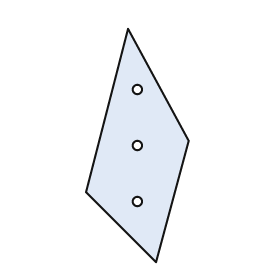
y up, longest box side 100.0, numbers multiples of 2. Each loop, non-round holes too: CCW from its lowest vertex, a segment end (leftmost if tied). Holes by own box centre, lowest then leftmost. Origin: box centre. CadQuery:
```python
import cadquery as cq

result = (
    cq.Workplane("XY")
    .moveTo(8.0, -50.0)
    .lineTo(22.0, 2.0)
    .lineTo(-4.0, 50.0)
    .lineTo(-22.0, -20.0)
    .close()
    .moveTo(0.0, -24.0)
    .circle(2.0)
    .moveTo(0.0, 0.0)
    .circle(2.0)
    .moveTo(0.0, 24.0)
    .circle(2.0)
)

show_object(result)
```